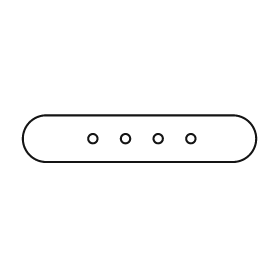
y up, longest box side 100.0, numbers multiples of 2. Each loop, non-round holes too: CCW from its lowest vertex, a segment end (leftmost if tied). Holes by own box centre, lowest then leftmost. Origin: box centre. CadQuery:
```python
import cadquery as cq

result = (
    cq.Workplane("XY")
    .moveTo(-40.0, -10.0)
    .lineTo(40.0, -10.0)
    .threePointArc((50.0, 0.0), (40.0, 10.0))
    .lineTo(-40.0, 10.0)
    .threePointArc((-50.0, 0.0), (-40.0, -10.0))
    .close()
    .moveTo(-20.0, 0.0)
    .circle(2.0)
    .moveTo(-6.0, 0.0)
    .circle(2.0)
    .moveTo(8.0, 0.0)
    .circle(2.0)
    .moveTo(22.0, 0.0)
    .circle(2.0)
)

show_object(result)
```